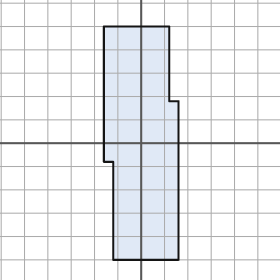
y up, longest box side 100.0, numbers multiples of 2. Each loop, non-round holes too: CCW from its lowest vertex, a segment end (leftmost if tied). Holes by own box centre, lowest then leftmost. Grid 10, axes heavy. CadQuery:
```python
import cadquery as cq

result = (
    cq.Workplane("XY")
    .moveTo(-12.0, -50.0)
    .lineTo(16.0, -50.0)
    .lineTo(16.0, 18.0)
    .lineTo(12.0, 18.0)
    .lineTo(12.0, 50.0)
    .lineTo(-16.0, 50.0)
    .lineTo(-16.0, -8.0)
    .lineTo(-12.0, -8.0)
    .close()
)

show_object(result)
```